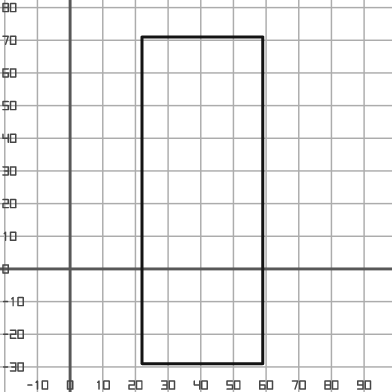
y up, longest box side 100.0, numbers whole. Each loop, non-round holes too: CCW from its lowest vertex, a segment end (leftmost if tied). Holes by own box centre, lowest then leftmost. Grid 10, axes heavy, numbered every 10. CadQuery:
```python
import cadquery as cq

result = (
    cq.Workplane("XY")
    .moveTo(22.0, -29.0)
    .lineTo(59.0, -29.0)
    .lineTo(59.0, 71.0)
    .lineTo(22.0, 71.0)
    .close()
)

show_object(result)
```